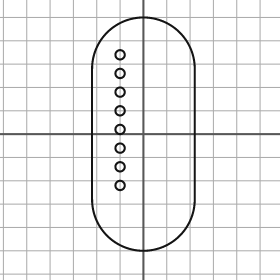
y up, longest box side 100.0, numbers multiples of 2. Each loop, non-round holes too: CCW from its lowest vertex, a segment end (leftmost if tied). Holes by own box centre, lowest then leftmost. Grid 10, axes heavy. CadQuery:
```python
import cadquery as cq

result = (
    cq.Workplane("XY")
    .moveTo(-22.0, -28.0)
    .threePointArc((0.0, -50.0), (22.0, -28.0))
    .lineTo(22.0, 28.0)
    .threePointArc((0.0, 50.0), (-22.0, 28.0))
    .close()
    .moveTo(-10.0, -22.0)
    .circle(2.0)
    .moveTo(-10.0, -14.0)
    .circle(2.0)
    .moveTo(-10.0, -6.0)
    .circle(2.0)
    .moveTo(-10.0, 2.0)
    .circle(2.0)
    .moveTo(-10.0, 10.0)
    .circle(2.0)
    .moveTo(-10.0, 18.0)
    .circle(2.0)
    .moveTo(-10.0, 26.0)
    .circle(2.0)
    .moveTo(-10.0, 34.0)
    .circle(2.0)
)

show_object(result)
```